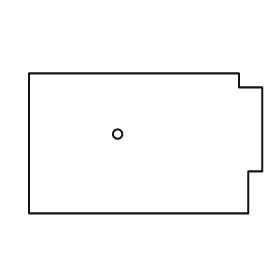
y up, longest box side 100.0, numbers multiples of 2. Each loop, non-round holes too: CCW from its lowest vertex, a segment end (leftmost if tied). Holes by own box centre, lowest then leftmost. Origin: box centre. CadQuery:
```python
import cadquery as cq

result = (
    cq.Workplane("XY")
    .moveTo(-50.0, -30.0)
    .lineTo(44.0, -30.0)
    .lineTo(44.0, -12.0)
    .lineTo(50.0, -12.0)
    .lineTo(50.0, 24.0)
    .lineTo(40.0, 24.0)
    .lineTo(40.0, 30.0)
    .lineTo(-50.0, 30.0)
    .close()
    .moveTo(-12.0, 4.0)
    .circle(2.0)
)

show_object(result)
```